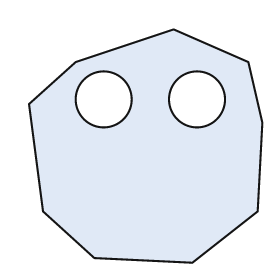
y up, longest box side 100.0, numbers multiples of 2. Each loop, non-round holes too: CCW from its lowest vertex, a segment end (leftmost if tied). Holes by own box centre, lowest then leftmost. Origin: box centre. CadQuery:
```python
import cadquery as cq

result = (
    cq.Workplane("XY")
    .moveTo(20.0, -50.0)
    .lineTo(48.0, -28.0)
    .lineTo(50.0, 10.0)
    .lineTo(44.0, 36.0)
    .lineTo(12.0, 50.0)
    .lineTo(-30.0, 36.0)
    .lineTo(-50.0, 18.0)
    .lineTo(-44.0, -28.0)
    .lineTo(-22.0, -48.0)
    .close()
    .moveTo(-18.0, 20.0)
    .circle(12.0)
    .moveTo(22.0, 20.0)
    .circle(12.0)
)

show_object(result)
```